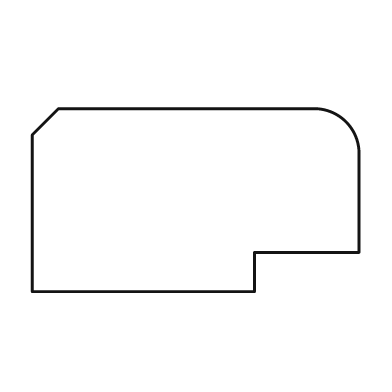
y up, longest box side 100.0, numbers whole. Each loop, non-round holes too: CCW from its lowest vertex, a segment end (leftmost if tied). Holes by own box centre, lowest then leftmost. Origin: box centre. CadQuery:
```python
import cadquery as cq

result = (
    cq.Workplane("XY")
    .moveTo(-50.0, -28.0)
    .lineTo(18.0, -28.0)
    .lineTo(18.0, -16.0)
    .lineTo(50.0, -16.0)
    .lineTo(50.0, 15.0)
    .threePointArc((46.0, 24.0), (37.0, 28.0))
    .lineTo(-42.0, 28.0)
    .lineTo(-50.0, 20.0)
    .close()
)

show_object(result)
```